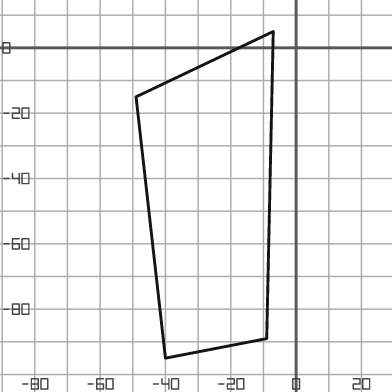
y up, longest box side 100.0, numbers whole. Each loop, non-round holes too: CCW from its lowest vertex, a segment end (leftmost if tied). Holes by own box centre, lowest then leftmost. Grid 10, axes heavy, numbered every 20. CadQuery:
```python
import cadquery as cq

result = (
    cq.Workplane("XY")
    .moveTo(-40.0, -95.0)
    .lineTo(-9.0, -89.0)
    .lineTo(-7.0, 5.0)
    .lineTo(-49.0, -15.0)
    .close()
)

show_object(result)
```